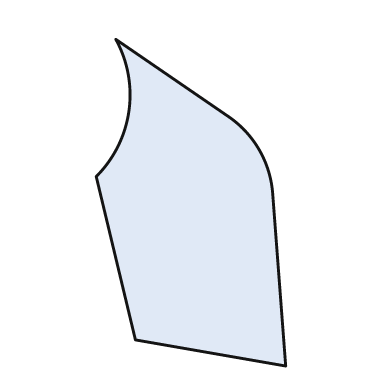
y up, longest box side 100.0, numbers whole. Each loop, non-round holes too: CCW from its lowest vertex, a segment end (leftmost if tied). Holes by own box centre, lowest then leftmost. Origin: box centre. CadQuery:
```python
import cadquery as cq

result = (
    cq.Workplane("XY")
    .moveTo(29.0, -50.0)
    .lineTo(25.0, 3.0)
    .threePointArc((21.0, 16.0), (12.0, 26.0))
    .lineTo(-23.0, 50.0)
    .threePointArc((-19.0, 28.0), (-29.0, 8.0))
    .lineTo(-17.0, -42.0)
    .close()
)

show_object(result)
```